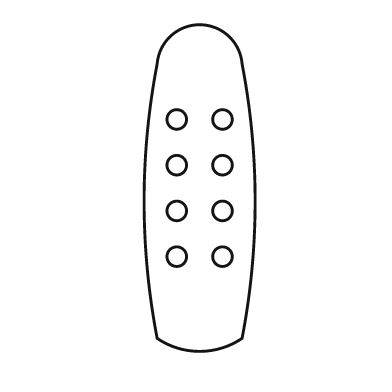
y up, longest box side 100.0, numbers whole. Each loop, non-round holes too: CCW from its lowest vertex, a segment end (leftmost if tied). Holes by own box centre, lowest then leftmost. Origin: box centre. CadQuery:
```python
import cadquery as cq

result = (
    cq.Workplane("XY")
    .moveTo(-13.0, -46.0)
    .threePointArc((0.0, -50.0), (13.0, -46.0))
    .threePointArc((17.0, -4.0), (13.0, 38.0))
    .threePointArc((0.0, 50.0), (-13.0, 38.0))
    .threePointArc((-17.0, -4.0), (-13.0, -46.0))
    .close()
    .moveTo(-7.0, -21.0)
    .circle(3.0)
    .moveTo(7.0, -21.0)
    .circle(3.0)
    .moveTo(-7.0, -7.0)
    .circle(3.0)
    .moveTo(7.0, -7.0)
    .circle(3.0)
    .moveTo(-7.0, 7.0)
    .circle(3.0)
    .moveTo(7.0, 7.0)
    .circle(3.0)
    .moveTo(-7.0, 21.0)
    .circle(3.0)
    .moveTo(7.0, 21.0)
    .circle(3.0)
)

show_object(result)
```